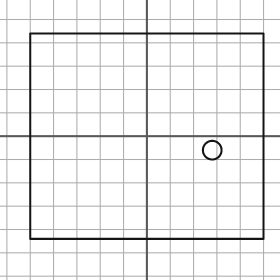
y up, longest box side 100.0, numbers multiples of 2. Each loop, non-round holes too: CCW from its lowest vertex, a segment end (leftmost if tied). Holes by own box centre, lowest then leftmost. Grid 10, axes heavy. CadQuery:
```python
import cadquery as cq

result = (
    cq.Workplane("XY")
    .moveTo(-50.0, -44.0)
    .lineTo(50.0, -44.0)
    .lineTo(50.0, 44.0)
    .lineTo(-50.0, 44.0)
    .close()
    .moveTo(28.0, -6.0)
    .circle(4.0)
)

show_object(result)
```